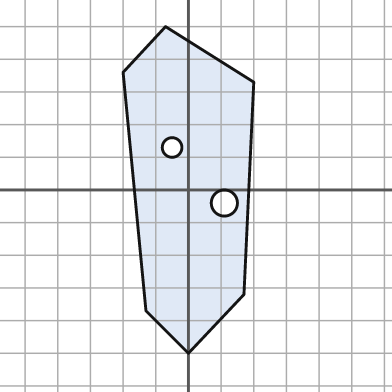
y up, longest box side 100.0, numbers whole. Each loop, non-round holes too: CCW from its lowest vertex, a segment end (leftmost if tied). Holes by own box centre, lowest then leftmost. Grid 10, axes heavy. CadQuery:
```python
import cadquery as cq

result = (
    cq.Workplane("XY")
    .moveTo(0.0, -50.0)
    .lineTo(17.0, -32.0)
    .lineTo(20.0, 33.0)
    .lineTo(-7.0, 50.0)
    .lineTo(-20.0, 36.0)
    .lineTo(-13.0, -37.0)
    .close()
    .moveTo(11.0, -4.0)
    .circle(4.0)
    .moveTo(-5.0, 13.0)
    .circle(3.0)
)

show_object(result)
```